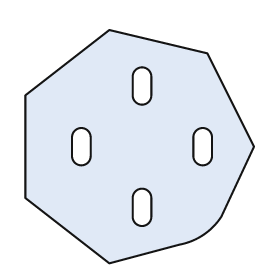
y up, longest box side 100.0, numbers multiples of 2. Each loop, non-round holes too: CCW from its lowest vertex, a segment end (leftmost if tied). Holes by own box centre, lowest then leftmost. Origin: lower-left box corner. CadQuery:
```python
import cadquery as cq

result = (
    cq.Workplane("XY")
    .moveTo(36.0, 0.0)
    .lineTo(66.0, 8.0)
    .threePointArc((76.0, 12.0), (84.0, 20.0))
    .lineTo(98.0, 50.0)
    .lineTo(78.0, 90.0)
    .lineTo(36.0, 100.0)
    .lineTo(0.0, 72.0)
    .lineTo(0.0, 28.0)
    .close()
    .moveTo(46.0, 20.0)
    .threePointArc((50.0, 16.0), (54.0, 20.0))
    .lineTo(54.0, 28.0)
    .threePointArc((50.0, 32.0), (46.0, 28.0))
    .close()
    .moveTo(20.0, 46.0)
    .threePointArc((24.0, 42.0), (28.0, 46.0))
    .lineTo(28.0, 54.0)
    .threePointArc((24.0, 58.0), (20.0, 54.0))
    .close()
    .moveTo(72.0, 46.0)
    .threePointArc((76.0, 42.0), (80.0, 46.0))
    .lineTo(80.0, 54.0)
    .threePointArc((76.0, 58.0), (72.0, 54.0))
    .close()
    .moveTo(46.0, 72.0)
    .threePointArc((50.0, 68.0), (54.0, 72.0))
    .lineTo(54.0, 80.0)
    .threePointArc((50.0, 84.0), (46.0, 80.0))
    .close()
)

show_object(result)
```